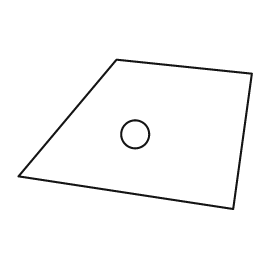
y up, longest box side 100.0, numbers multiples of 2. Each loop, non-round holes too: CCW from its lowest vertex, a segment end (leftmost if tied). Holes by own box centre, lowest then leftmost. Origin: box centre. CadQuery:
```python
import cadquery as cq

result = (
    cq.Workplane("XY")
    .moveTo(42.0, -32.0)
    .lineTo(50.0, 26.0)
    .lineTo(-8.0, 32.0)
    .lineTo(-50.0, -18.0)
    .close()
    .moveTo(0.0, 0.0)
    .circle(6.0)
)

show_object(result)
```